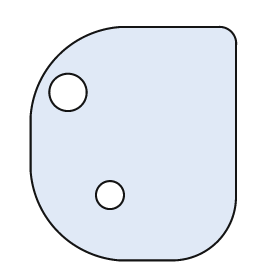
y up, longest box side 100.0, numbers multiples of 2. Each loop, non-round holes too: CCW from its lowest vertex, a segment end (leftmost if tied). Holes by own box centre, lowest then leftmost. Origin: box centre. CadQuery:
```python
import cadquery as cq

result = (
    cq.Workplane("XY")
    .moveTo(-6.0, -50.0)
    .lineTo(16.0, -50.0)
    .threePointArc((36.0, -42.0), (44.0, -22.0))
    .lineTo(44.0, 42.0)
    .threePointArc((42.0, 48.0), (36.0, 50.0))
    .lineTo(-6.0, 50.0)
    .threePointArc((-32.0, 38.0), (-44.0, 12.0))
    .lineTo(-44.0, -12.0)
    .threePointArc((-32.0, -38.0), (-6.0, -50.0))
    .close()
    .moveTo(-10.0, -22.0)
    .circle(6.0)
    .moveTo(-28.0, 22.0)
    .circle(8.0)
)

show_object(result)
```